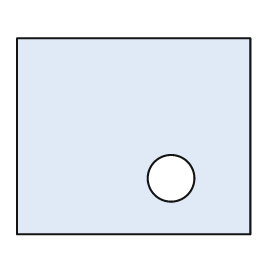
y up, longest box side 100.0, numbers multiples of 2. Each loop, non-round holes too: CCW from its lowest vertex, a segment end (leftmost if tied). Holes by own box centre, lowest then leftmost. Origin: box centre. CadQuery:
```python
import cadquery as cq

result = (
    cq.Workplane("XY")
    .moveTo(-50.0, -42.0)
    .lineTo(50.0, -42.0)
    .lineTo(50.0, 42.0)
    .lineTo(-50.0, 42.0)
    .close()
    .moveTo(16.0, -18.0)
    .circle(10.0)
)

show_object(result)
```